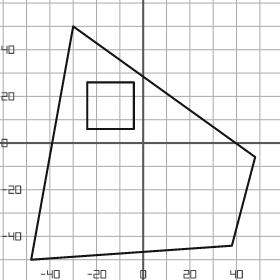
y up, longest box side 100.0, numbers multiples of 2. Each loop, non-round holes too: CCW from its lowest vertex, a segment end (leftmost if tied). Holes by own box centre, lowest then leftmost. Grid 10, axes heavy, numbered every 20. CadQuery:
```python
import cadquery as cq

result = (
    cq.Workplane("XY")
    .moveTo(-48.0, -50.0)
    .lineTo(38.0, -44.0)
    .lineTo(48.0, -6.0)
    .lineTo(-30.0, 50.0)
    .close()
    .moveTo(-24.0, 6.0)
    .lineTo(-4.0, 6.0)
    .lineTo(-4.0, 26.0)
    .lineTo(-24.0, 26.0)
    .close()
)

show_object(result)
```